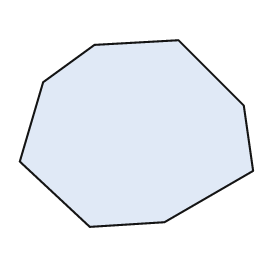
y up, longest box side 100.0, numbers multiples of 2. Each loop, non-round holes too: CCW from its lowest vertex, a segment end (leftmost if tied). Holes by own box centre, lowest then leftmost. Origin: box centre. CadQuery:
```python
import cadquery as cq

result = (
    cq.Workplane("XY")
    .moveTo(-20.0, -40.0)
    .lineTo(12.0, -38.0)
    .lineTo(50.0, -16.0)
    .lineTo(46.0, 12.0)
    .lineTo(18.0, 40.0)
    .lineTo(-18.0, 38.0)
    .lineTo(-40.0, 22.0)
    .lineTo(-50.0, -12.0)
    .close()
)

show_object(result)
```